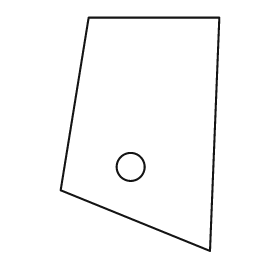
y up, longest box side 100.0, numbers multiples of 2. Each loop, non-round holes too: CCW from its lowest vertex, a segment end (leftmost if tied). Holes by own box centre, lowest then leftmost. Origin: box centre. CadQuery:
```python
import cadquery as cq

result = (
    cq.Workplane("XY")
    .moveTo(30.0, -50.0)
    .lineTo(34.0, 50.0)
    .lineTo(-22.0, 50.0)
    .lineTo(-34.0, -24.0)
    .close()
    .moveTo(-4.0, -14.0)
    .circle(6.0)
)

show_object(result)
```